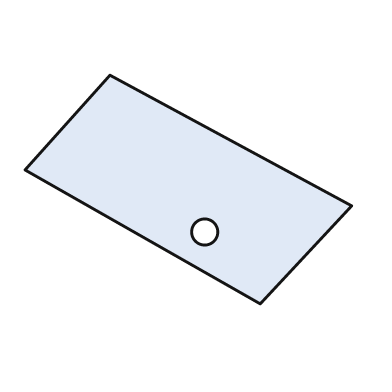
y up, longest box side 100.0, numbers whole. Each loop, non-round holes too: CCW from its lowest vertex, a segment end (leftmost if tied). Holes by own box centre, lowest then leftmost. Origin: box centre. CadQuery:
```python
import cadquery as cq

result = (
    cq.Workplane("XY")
    .moveTo(22.0, -35.0)
    .lineTo(50.0, -5.0)
    .lineTo(-24.0, 35.0)
    .lineTo(-50.0, 6.0)
    .close()
    .moveTo(5.0, -13.0)
    .circle(4.0)
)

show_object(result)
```